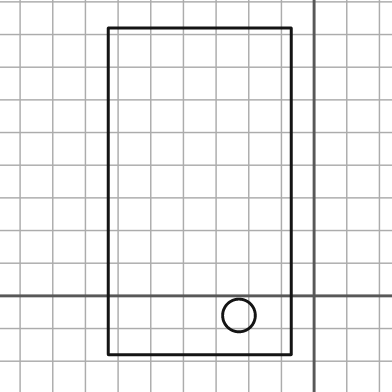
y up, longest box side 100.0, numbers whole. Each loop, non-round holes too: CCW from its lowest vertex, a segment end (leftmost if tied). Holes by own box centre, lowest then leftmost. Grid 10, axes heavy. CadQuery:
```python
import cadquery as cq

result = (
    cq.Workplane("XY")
    .moveTo(-63.0, -18.0)
    .lineTo(-7.0, -18.0)
    .lineTo(-7.0, 82.0)
    .lineTo(-63.0, 82.0)
    .close()
    .moveTo(-23.0, -6.0)
    .circle(5.0)
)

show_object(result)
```